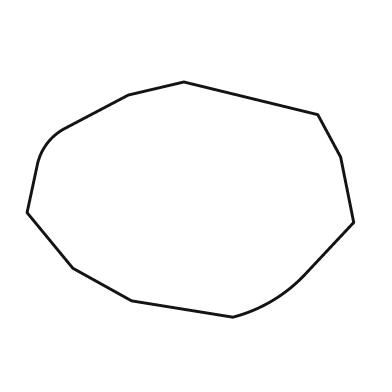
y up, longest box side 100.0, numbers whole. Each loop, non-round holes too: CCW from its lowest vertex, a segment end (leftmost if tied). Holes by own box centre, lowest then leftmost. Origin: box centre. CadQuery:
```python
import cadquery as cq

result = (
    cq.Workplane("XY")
    .moveTo(13.0, -36.0)
    .threePointArc((25.0, -31.0), (35.0, -23.0))
    .lineTo(50.0, -7.0)
    .lineTo(46.0, 13.0)
    .lineTo(39.0, 26.0)
    .lineTo(-2.0, 36.0)
    .lineTo(-19.0, 32.0)
    .lineTo(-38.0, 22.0)
    .threePointArc((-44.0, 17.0), (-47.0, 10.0))
    .lineTo(-50.0, -4.0)
    .lineTo(-36.0, -21.0)
    .lineTo(-18.0, -31.0)
    .close()
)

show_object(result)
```